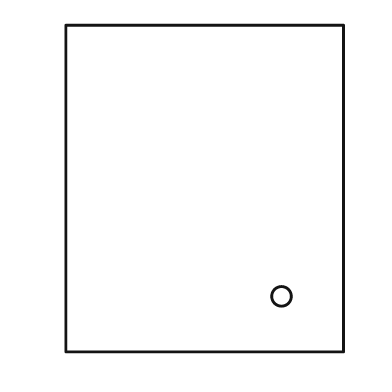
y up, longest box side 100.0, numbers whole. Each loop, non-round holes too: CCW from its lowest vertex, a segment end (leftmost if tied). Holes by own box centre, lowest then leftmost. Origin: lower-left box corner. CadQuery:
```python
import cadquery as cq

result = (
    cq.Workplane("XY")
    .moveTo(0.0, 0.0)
    .lineTo(85.0, 0.0)
    .lineTo(85.0, 100.0)
    .lineTo(0.0, 100.0)
    .close()
    .moveTo(66.0, 17.0)
    .circle(3.0)
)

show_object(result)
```